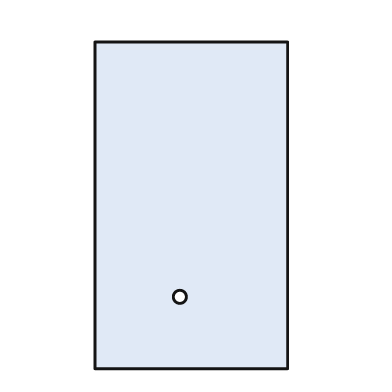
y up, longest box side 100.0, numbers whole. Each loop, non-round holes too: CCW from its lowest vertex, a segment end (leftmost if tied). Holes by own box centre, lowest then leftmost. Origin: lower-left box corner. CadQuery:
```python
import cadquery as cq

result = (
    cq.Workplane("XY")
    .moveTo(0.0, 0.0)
    .lineTo(59.0, 0.0)
    .lineTo(59.0, 100.0)
    .lineTo(0.0, 100.0)
    .close()
    .moveTo(26.0, 22.0)
    .circle(2.0)
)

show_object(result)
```